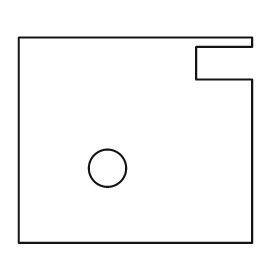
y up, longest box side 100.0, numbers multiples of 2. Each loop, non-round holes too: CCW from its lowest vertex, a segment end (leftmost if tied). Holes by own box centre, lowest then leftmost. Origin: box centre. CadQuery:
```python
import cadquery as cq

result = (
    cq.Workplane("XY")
    .moveTo(-50.0, -44.0)
    .lineTo(50.0, -44.0)
    .lineTo(50.0, 26.0)
    .lineTo(26.0, 26.0)
    .lineTo(26.0, 40.0)
    .lineTo(50.0, 40.0)
    .lineTo(50.0, 44.0)
    .lineTo(-50.0, 44.0)
    .close()
    .moveTo(-12.0, -12.0)
    .circle(8.0)
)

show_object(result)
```